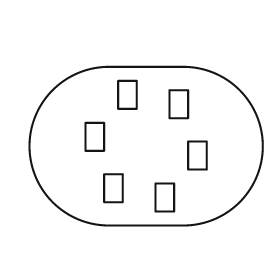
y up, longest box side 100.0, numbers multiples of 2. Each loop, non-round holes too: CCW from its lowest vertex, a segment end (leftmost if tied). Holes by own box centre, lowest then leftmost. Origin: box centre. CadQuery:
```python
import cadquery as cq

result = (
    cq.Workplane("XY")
    .moveTo(-16.0, -34.0)
    .lineTo(16.0, -34.0)
    .threePointArc((50.0, 0.0), (16.0, 34.0))
    .lineTo(-16.0, 34.0)
    .threePointArc((-50.0, 0.0), (-16.0, -34.0))
    .close()
    .moveTo(4.0, -28.0)
    .lineTo(12.0, -28.0)
    .lineTo(12.0, -16.0)
    .lineTo(4.0, -16.0)
    .close()
    .moveTo(-18.0, -24.0)
    .lineTo(-10.0, -24.0)
    .lineTo(-10.0, -12.0)
    .lineTo(-18.0, -12.0)
    .close()
    .moveTo(18.0, -10.0)
    .lineTo(26.0, -10.0)
    .lineTo(26.0, 2.0)
    .lineTo(18.0, 2.0)
    .close()
    .moveTo(-26.0, -2.0)
    .lineTo(-18.0, -2.0)
    .lineTo(-18.0, 10.0)
    .lineTo(-26.0, 10.0)
    .close()
    .moveTo(10.0, 12.0)
    .lineTo(18.0, 12.0)
    .lineTo(18.0, 24.0)
    .lineTo(10.0, 24.0)
    .close()
    .moveTo(-12.0, 16.0)
    .lineTo(-4.0, 16.0)
    .lineTo(-4.0, 28.0)
    .lineTo(-12.0, 28.0)
    .close()
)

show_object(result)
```